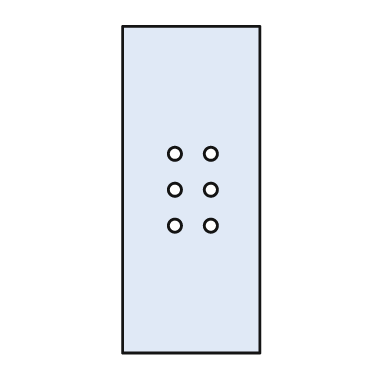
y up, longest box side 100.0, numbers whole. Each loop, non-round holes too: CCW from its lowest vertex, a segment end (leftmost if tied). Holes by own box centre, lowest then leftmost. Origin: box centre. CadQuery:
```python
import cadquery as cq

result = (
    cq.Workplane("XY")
    .moveTo(-21.0, -50.0)
    .lineTo(21.0, -50.0)
    .lineTo(21.0, 50.0)
    .lineTo(-21.0, 50.0)
    .close()
    .moveTo(-5.0, -11.0)
    .circle(2.0)
    .moveTo(6.0, -11.0)
    .circle(2.0)
    .moveTo(-5.0, 0.0)
    .circle(2.0)
    .moveTo(6.0, 0.0)
    .circle(2.0)
    .moveTo(-5.0, 11.0)
    .circle(2.0)
    .moveTo(6.0, 11.0)
    .circle(2.0)
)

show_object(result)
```